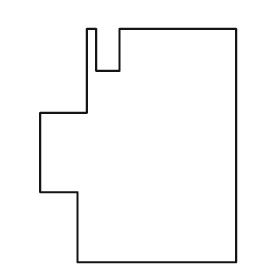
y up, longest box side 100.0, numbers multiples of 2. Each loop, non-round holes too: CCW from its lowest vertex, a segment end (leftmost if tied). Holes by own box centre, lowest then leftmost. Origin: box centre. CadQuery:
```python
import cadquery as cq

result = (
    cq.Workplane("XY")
    .moveTo(-26.0, -50.0)
    .lineTo(42.0, -50.0)
    .lineTo(42.0, 50.0)
    .lineTo(-8.0, 50.0)
    .lineTo(-8.0, 32.0)
    .lineTo(-18.0, 32.0)
    .lineTo(-18.0, 50.0)
    .lineTo(-22.0, 50.0)
    .lineTo(-22.0, 14.0)
    .lineTo(-42.0, 14.0)
    .lineTo(-42.0, -20.0)
    .lineTo(-26.0, -20.0)
    .close()
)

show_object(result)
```